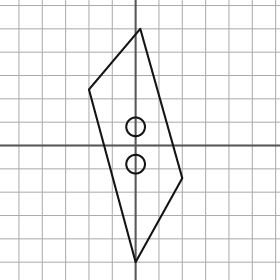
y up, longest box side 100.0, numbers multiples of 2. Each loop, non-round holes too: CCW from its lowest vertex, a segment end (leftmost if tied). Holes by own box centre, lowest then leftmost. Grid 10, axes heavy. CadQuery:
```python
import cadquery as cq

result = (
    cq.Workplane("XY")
    .moveTo(0.0, -50.0)
    .lineTo(20.0, -14.0)
    .lineTo(2.0, 50.0)
    .lineTo(-20.0, 24.0)
    .close()
    .moveTo(0.0, -8.0)
    .circle(4.0)
    .moveTo(0.0, 8.0)
    .circle(4.0)
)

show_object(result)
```